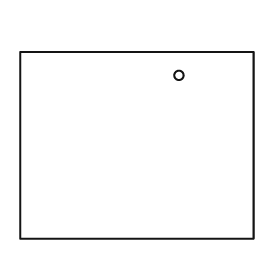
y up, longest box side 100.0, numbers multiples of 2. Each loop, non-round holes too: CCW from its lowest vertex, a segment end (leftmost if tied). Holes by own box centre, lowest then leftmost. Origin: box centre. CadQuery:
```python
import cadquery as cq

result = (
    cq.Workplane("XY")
    .moveTo(-50.0, -40.0)
    .lineTo(50.0, -40.0)
    .lineTo(50.0, 40.0)
    .lineTo(-50.0, 40.0)
    .close()
    .moveTo(18.0, 30.0)
    .circle(2.0)
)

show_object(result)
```